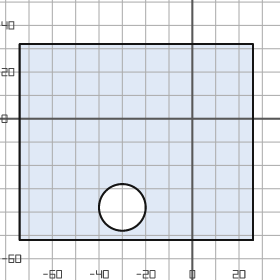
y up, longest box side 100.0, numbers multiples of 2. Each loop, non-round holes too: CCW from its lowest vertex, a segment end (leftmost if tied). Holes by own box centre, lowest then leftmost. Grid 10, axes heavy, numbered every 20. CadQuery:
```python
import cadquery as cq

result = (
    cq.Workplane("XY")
    .moveTo(-74.0, -52.0)
    .lineTo(26.0, -52.0)
    .lineTo(26.0, 32.0)
    .lineTo(-74.0, 32.0)
    .close()
    .moveTo(-30.0, -38.0)
    .circle(10.0)
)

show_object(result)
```